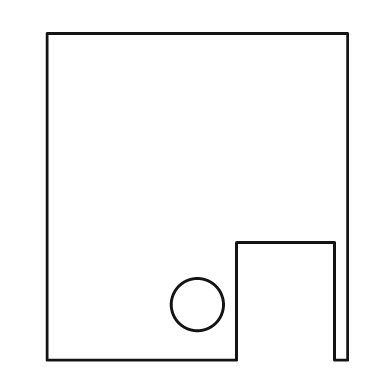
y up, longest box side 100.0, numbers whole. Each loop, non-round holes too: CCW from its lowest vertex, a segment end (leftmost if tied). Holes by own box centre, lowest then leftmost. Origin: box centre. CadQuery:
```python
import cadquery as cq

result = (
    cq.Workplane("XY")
    .moveTo(-46.0, -50.0)
    .lineTo(12.0, -50.0)
    .lineTo(12.0, -14.0)
    .lineTo(42.0, -14.0)
    .lineTo(42.0, -50.0)
    .lineTo(46.0, -50.0)
    .lineTo(46.0, 50.0)
    .lineTo(-46.0, 50.0)
    .close()
    .moveTo(0.0, -33.0)
    .circle(8.0)
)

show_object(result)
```